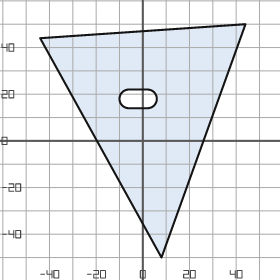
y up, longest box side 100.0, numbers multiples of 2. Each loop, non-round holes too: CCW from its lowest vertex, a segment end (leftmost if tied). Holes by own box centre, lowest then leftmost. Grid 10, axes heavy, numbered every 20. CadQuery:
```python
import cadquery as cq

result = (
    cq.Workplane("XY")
    .moveTo(8.0, -50.0)
    .lineTo(44.0, 50.0)
    .lineTo(-44.0, 44.0)
    .close()
    .moveTo(-6.0, 14.0)
    .lineTo(2.0, 14.0)
    .threePointArc((6.0, 18.0), (2.0, 22.0))
    .lineTo(-6.0, 22.0)
    .threePointArc((-10.0, 18.0), (-6.0, 14.0))
    .close()
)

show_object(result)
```